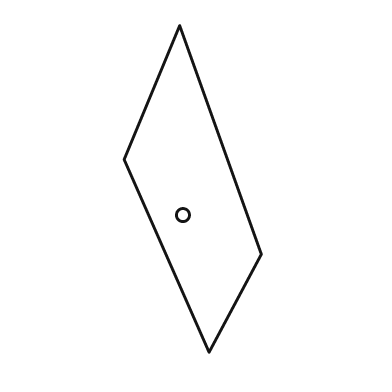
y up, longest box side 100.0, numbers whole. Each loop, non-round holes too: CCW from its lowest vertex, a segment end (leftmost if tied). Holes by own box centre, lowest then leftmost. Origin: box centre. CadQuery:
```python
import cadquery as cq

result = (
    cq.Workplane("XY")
    .moveTo(5.0, -50.0)
    .lineTo(21.0, -20.0)
    .lineTo(-4.0, 50.0)
    .lineTo(-21.0, 9.0)
    .close()
    .moveTo(-3.0, -8.0)
    .circle(2.0)
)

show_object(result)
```